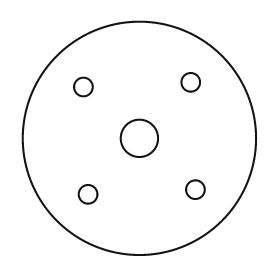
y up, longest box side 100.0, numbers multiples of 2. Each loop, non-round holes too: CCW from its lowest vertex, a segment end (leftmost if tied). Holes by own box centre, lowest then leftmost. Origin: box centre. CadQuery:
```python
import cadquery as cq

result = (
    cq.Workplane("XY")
    .moveTo(0.0, 0.0)
    .circle(50.0)
    .moveTo(-22.0, -24.0)
    .circle(4.0)
    .moveTo(24.0, -22.0)
    .circle(4.0)
    .moveTo(0.0, 0.0)
    .circle(8.0)
    .moveTo(-24.0, 22.0)
    .circle(4.0)
    .moveTo(22.0, 24.0)
    .circle(4.0)
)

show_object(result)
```